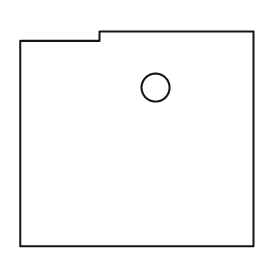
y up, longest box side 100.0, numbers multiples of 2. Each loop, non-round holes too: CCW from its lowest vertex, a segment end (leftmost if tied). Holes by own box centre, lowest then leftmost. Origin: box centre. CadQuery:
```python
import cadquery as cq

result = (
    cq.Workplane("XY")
    .moveTo(-50.0, -46.0)
    .lineTo(50.0, -46.0)
    .lineTo(50.0, 46.0)
    .lineTo(-16.0, 46.0)
    .lineTo(-16.0, 42.0)
    .lineTo(-50.0, 42.0)
    .close()
    .moveTo(8.0, 22.0)
    .circle(6.0)
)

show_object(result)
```